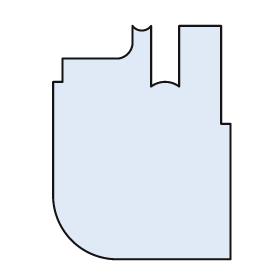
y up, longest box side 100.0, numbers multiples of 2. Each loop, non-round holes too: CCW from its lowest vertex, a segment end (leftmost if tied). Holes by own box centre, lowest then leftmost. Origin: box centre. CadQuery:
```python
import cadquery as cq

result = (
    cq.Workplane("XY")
    .moveTo(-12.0, -50.0)
    .lineTo(38.0, -50.0)
    .lineTo(38.0, 8.0)
    .lineTo(34.0, 8.0)
    .lineTo(34.0, 50.0)
    .lineTo(16.0, 50.0)
    .lineTo(16.0, 24.0)
    .threePointArc((10.0, 26.0), (4.0, 24.0))
    .lineTo(4.0, 50.0)
    .threePointArc((0.0, 48.0), (-4.0, 50.0))
    .lineTo(-4.0, 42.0)
    .threePointArc((-6.0, 38.0), (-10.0, 36.0))
    .lineTo(-34.0, 36.0)
    .lineTo(-34.0, 26.0)
    .lineTo(-38.0, 26.0)
    .lineTo(-38.0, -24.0)
    .threePointArc((-30.0, -42.0), (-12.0, -50.0))
    .close()
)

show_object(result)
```